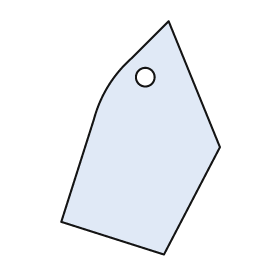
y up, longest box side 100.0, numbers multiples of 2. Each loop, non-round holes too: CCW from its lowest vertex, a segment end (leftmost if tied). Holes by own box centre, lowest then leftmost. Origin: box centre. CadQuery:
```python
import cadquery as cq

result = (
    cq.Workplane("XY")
    .moveTo(10.0, -50.0)
    .lineTo(34.0, -4.0)
    .lineTo(12.0, 50.0)
    .lineTo(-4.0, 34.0)
    .threePointArc((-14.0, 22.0), (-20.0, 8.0))
    .lineTo(-34.0, -36.0)
    .close()
    .moveTo(2.0, 26.0)
    .circle(4.0)
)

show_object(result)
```